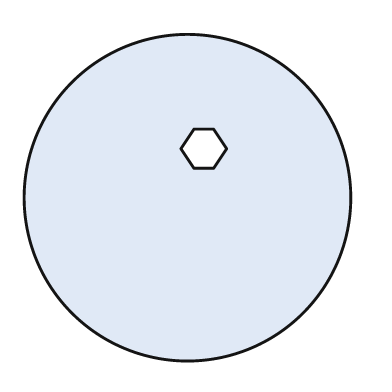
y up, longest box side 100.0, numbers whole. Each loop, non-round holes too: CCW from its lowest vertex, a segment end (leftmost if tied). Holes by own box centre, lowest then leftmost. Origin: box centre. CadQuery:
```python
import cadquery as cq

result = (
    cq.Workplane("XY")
    .moveTo(0.0, 0.0)
    .circle(50.0)
    .moveTo(2.0, 9.0)
    .lineTo(8.0, 9.0)
    .lineTo(12.0, 15.0)
    .lineTo(8.0, 21.0)
    .lineTo(2.0, 21.0)
    .lineTo(-2.0, 15.0)
    .close()
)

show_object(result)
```